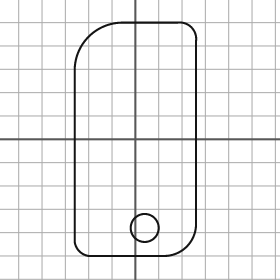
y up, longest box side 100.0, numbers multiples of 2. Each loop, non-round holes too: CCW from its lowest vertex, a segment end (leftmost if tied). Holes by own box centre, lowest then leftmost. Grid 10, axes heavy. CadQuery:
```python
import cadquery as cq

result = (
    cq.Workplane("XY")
    .moveTo(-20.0, -50.0)
    .lineTo(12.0, -50.0)
    .threePointArc((22.0, -46.0), (26.0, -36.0))
    .lineTo(26.0, 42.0)
    .threePointArc((24.0, 48.0), (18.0, 50.0))
    .lineTo(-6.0, 50.0)
    .threePointArc((-20.0, 44.0), (-26.0, 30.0))
    .lineTo(-26.0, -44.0)
    .threePointArc((-24.0, -48.0), (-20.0, -50.0))
    .close()
    .moveTo(4.0, -38.0)
    .circle(6.0)
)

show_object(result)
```